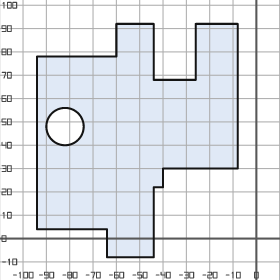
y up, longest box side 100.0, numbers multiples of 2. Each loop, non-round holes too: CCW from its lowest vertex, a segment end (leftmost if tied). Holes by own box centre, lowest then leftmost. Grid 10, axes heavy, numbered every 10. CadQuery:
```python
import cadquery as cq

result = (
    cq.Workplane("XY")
    .moveTo(-64.0, -8.0)
    .lineTo(-44.0, -8.0)
    .lineTo(-44.0, 22.0)
    .lineTo(-40.0, 22.0)
    .lineTo(-40.0, 30.0)
    .lineTo(-8.0, 30.0)
    .lineTo(-8.0, 92.0)
    .lineTo(-26.0, 92.0)
    .lineTo(-26.0, 68.0)
    .lineTo(-44.0, 68.0)
    .lineTo(-44.0, 92.0)
    .lineTo(-60.0, 92.0)
    .lineTo(-60.0, 78.0)
    .lineTo(-94.0, 78.0)
    .lineTo(-94.0, 4.0)
    .lineTo(-64.0, 4.0)
    .close()
    .moveTo(-82.0, 48.0)
    .circle(8.0)
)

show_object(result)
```